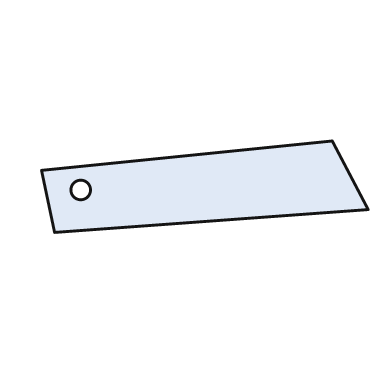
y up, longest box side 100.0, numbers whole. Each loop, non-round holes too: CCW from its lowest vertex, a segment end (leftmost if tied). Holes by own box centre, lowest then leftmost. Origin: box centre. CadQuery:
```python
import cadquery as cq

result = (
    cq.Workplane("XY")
    .moveTo(-46.0, -14.0)
    .lineTo(50.0, -7.0)
    .lineTo(39.0, 14.0)
    .lineTo(-50.0, 5.0)
    .close()
    .moveTo(-38.0, -1.0)
    .circle(3.0)
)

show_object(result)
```